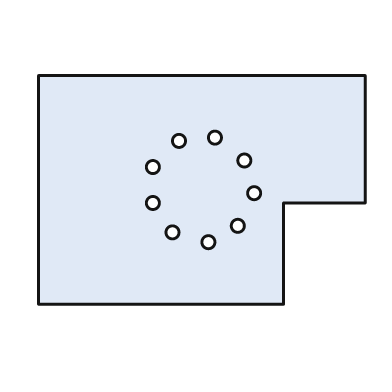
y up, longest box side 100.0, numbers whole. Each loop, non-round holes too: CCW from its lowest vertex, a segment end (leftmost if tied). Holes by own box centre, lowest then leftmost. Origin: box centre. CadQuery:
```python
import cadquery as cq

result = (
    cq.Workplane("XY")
    .moveTo(-50.0, -35.0)
    .lineTo(25.0, -35.0)
    .lineTo(25.0, -4.0)
    .lineTo(50.0, -4.0)
    .lineTo(50.0, 35.0)
    .lineTo(-50.0, 35.0)
    .close()
    .moveTo(2.0, -16.0)
    .circle(2.0)
    .moveTo(-9.0, -13.0)
    .circle(2.0)
    .moveTo(11.0, -11.0)
    .circle(2.0)
    .moveTo(-15.0, -4.0)
    .circle(2.0)
    .moveTo(16.0, -1.0)
    .circle(2.0)
    .moveTo(-15.0, 7.0)
    .circle(2.0)
    .moveTo(13.0, 9.0)
    .circle(2.0)
    .moveTo(-7.0, 15.0)
    .circle(2.0)
    .moveTo(4.0, 16.0)
    .circle(2.0)
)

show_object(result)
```